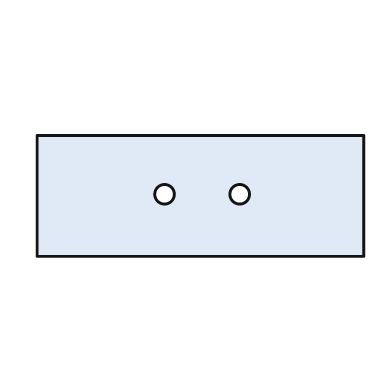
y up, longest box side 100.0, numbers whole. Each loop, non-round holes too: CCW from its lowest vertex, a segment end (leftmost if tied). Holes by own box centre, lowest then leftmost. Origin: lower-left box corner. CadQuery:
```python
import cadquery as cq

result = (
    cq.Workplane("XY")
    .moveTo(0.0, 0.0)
    .lineTo(100.0, 0.0)
    .lineTo(100.0, 37.0)
    .lineTo(0.0, 37.0)
    .close()
    .moveTo(39.0, 19.0)
    .circle(3.0)
    .moveTo(62.0, 19.0)
    .circle(3.0)
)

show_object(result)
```